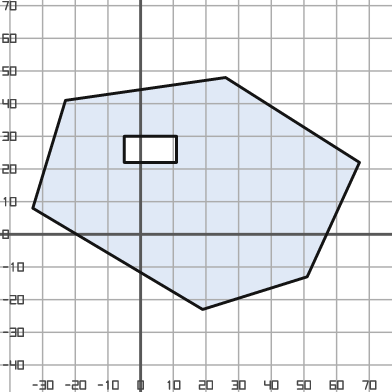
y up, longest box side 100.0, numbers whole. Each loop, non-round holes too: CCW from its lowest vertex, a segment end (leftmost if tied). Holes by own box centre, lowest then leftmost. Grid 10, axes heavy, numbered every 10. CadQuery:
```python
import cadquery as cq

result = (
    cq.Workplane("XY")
    .moveTo(19.0, -23.0)
    .lineTo(51.0, -13.0)
    .lineTo(67.0, 22.0)
    .lineTo(26.0, 48.0)
    .lineTo(-23.0, 41.0)
    .lineTo(-33.0, 8.0)
    .close()
    .moveTo(-5.0, 22.0)
    .lineTo(11.0, 22.0)
    .lineTo(11.0, 30.0)
    .lineTo(-5.0, 30.0)
    .close()
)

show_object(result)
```